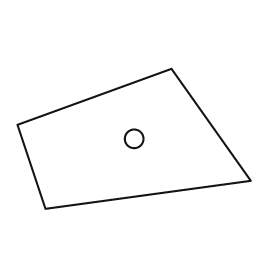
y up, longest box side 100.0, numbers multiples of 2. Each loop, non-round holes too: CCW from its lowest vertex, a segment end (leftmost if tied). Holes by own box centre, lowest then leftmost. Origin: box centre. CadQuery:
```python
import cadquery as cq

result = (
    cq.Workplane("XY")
    .moveTo(-38.0, -30.0)
    .lineTo(50.0, -18.0)
    .lineTo(16.0, 30.0)
    .lineTo(-50.0, 6.0)
    .close()
    .moveTo(0.0, 0.0)
    .circle(4.0)
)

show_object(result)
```